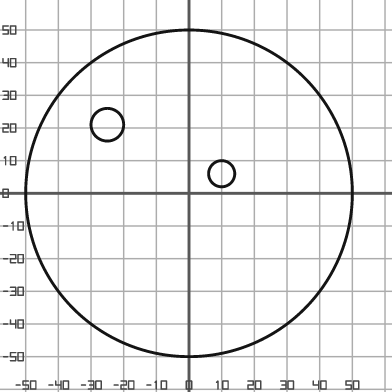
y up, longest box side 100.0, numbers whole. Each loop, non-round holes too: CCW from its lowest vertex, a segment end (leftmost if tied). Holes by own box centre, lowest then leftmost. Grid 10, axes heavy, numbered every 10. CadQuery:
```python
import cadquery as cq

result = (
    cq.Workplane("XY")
    .moveTo(0.0, 0.0)
    .circle(50.0)
    .moveTo(10.0, 6.0)
    .circle(4.0)
    .moveTo(-25.0, 21.0)
    .circle(5.0)
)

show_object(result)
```